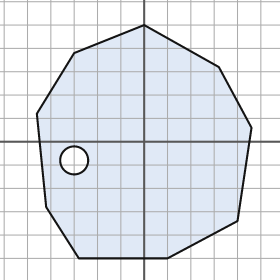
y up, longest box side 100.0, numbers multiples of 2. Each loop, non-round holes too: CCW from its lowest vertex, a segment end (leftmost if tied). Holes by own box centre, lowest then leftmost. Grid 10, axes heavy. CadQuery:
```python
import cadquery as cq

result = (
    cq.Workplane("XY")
    .moveTo(-28.0, -50.0)
    .lineTo(10.0, -50.0)
    .lineTo(40.0, -34.0)
    .lineTo(46.0, 6.0)
    .lineTo(32.0, 32.0)
    .lineTo(0.0, 50.0)
    .lineTo(-30.0, 38.0)
    .lineTo(-46.0, 12.0)
    .lineTo(-42.0, -28.0)
    .close()
    .moveTo(-30.0, -8.0)
    .circle(6.0)
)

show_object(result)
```